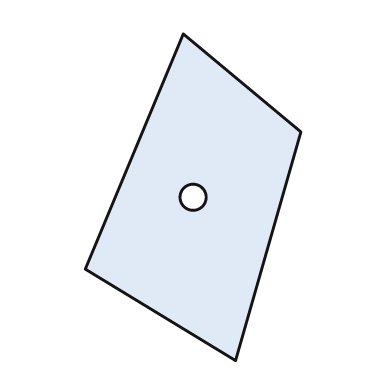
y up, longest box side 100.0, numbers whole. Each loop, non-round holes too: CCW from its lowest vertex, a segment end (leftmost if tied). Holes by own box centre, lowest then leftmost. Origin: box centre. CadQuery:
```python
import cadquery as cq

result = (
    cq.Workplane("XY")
    .moveTo(13.0, -50.0)
    .lineTo(33.0, 20.0)
    .lineTo(-3.0, 50.0)
    .lineTo(-33.0, -22.0)
    .close()
    .moveTo(0.0, 0.0)
    .circle(4.0)
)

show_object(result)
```